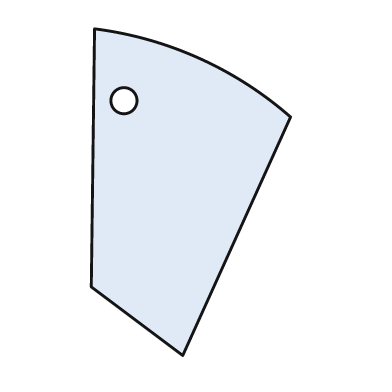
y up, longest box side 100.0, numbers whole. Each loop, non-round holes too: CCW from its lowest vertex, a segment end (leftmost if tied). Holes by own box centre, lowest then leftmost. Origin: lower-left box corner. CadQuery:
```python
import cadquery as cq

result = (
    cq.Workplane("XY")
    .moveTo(28.0, 0.0)
    .lineTo(61.0, 73.0)
    .threePointArc((33.0, 91.0), (1.0, 100.0))
    .lineTo(0.0, 21.0)
    .close()
    .moveTo(10.0, 78.0)
    .circle(4.0)
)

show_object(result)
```